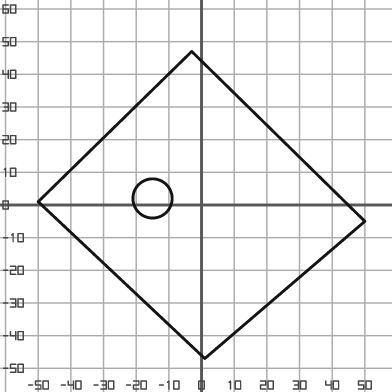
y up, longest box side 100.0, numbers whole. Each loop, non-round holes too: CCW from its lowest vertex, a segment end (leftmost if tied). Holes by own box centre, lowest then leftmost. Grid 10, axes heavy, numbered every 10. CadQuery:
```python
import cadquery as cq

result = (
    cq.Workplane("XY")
    .moveTo(1.0, -47.0)
    .lineTo(50.0, -5.0)
    .lineTo(-3.0, 47.0)
    .lineTo(-50.0, 1.0)
    .close()
    .moveTo(-15.0, 2.0)
    .circle(6.0)
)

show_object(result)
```